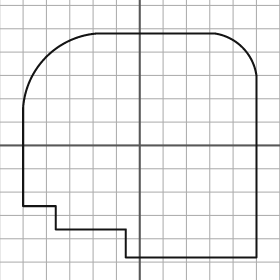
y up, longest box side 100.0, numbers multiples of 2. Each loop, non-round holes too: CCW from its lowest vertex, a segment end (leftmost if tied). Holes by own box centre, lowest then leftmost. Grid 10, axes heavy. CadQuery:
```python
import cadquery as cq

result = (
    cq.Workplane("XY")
    .moveTo(-6.0, -48.0)
    .lineTo(50.0, -48.0)
    .lineTo(50.0, 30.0)
    .threePointArc((44.0, 42.0), (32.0, 48.0))
    .lineTo(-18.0, 48.0)
    .threePointArc((-40.0, 38.0), (-50.0, 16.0))
    .lineTo(-50.0, -26.0)
    .lineTo(-36.0, -26.0)
    .lineTo(-36.0, -36.0)
    .lineTo(-6.0, -36.0)
    .close()
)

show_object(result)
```